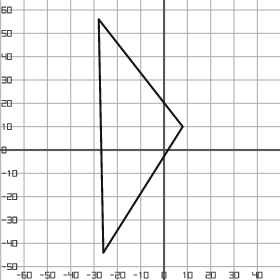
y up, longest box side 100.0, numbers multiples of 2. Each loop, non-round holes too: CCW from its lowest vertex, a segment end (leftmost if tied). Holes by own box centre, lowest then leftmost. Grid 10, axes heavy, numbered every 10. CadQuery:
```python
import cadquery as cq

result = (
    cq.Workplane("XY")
    .moveTo(-26.0, -44.0)
    .lineTo(8.0, 10.0)
    .lineTo(-28.0, 56.0)
    .close()
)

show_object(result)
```